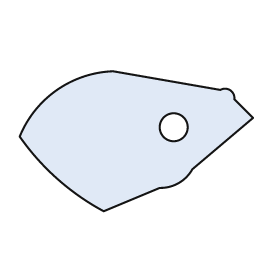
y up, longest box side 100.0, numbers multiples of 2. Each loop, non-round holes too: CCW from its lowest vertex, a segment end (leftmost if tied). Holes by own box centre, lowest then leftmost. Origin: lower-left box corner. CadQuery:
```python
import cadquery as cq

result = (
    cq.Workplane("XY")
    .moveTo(36.0, 0.0)
    .lineTo(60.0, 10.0)
    .threePointArc((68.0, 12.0), (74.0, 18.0))
    .lineTo(100.0, 40.0)
    .lineTo(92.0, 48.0)
    .threePointArc((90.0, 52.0), (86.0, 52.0))
    .lineTo(40.0, 60.0)
    .threePointArc((16.0, 52.0), (0.0, 32.0))
    .threePointArc((16.0, 14.0), (36.0, 0.0))
    .close()
    .moveTo(66.0, 36.0)
    .circle(6.0)
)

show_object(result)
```